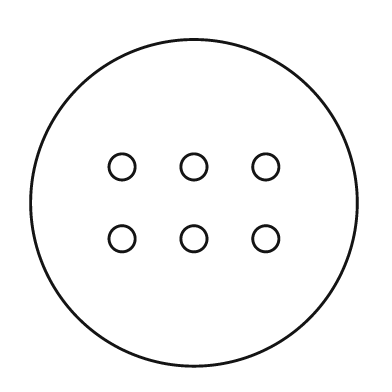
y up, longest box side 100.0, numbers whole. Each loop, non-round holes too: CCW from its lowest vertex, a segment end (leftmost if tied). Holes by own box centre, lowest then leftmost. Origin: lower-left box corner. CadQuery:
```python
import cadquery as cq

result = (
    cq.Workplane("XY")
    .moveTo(50.0, 50.0)
    .circle(50.0)
    .moveTo(28.0, 39.0)
    .circle(4.0)
    .moveTo(50.0, 39.0)
    .circle(4.0)
    .moveTo(72.0, 39.0)
    .circle(4.0)
    .moveTo(28.0, 61.0)
    .circle(4.0)
    .moveTo(50.0, 61.0)
    .circle(4.0)
    .moveTo(72.0, 61.0)
    .circle(4.0)
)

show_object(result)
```